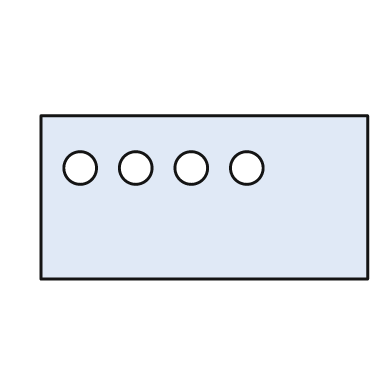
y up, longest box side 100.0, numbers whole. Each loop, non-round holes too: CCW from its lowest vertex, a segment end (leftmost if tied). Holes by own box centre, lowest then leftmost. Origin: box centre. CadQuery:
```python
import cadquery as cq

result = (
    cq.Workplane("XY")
    .moveTo(-50.0, -25.0)
    .lineTo(50.0, -25.0)
    .lineTo(50.0, 25.0)
    .lineTo(-50.0, 25.0)
    .close()
    .moveTo(-38.0, 9.0)
    .circle(5.0)
    .moveTo(-21.0, 9.0)
    .circle(5.0)
    .moveTo(-4.0, 9.0)
    .circle(5.0)
    .moveTo(13.0, 9.0)
    .circle(5.0)
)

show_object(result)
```